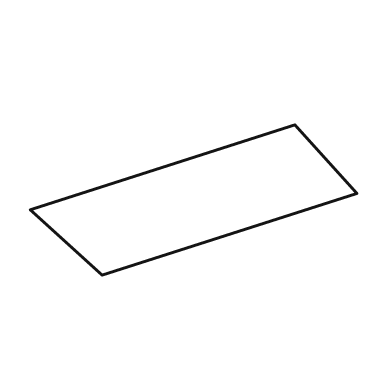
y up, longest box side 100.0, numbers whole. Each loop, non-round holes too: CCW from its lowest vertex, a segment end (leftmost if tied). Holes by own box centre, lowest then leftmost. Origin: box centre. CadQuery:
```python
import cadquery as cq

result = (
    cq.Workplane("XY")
    .moveTo(-28.0, -23.0)
    .lineTo(50.0, 2.0)
    .lineTo(31.0, 23.0)
    .lineTo(-50.0, -3.0)
    .close()
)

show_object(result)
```